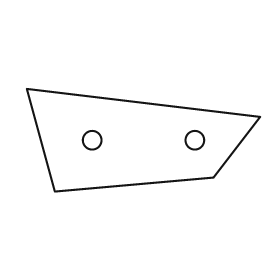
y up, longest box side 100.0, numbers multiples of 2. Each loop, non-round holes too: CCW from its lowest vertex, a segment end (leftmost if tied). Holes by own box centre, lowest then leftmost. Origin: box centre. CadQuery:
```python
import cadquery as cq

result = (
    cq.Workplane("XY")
    .moveTo(-38.0, -22.0)
    .lineTo(30.0, -16.0)
    .lineTo(50.0, 10.0)
    .lineTo(-50.0, 22.0)
    .close()
    .moveTo(-22.0, 0.0)
    .circle(4.0)
    .moveTo(22.0, 0.0)
    .circle(4.0)
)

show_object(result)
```